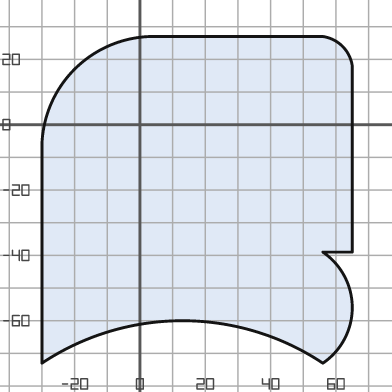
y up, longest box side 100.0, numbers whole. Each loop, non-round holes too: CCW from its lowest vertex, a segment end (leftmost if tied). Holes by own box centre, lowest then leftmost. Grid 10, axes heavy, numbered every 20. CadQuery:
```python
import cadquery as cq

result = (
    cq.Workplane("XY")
    .moveTo(-30.0, -73.0)
    .threePointArc((13.0, -60.0), (56.0, -73.0))
    .threePointArc((65.0, -56.0), (56.0, -39.0))
    .lineTo(65.0, -39.0)
    .lineTo(65.0, 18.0)
    .threePointArc((62.0, 24.0), (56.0, 27.0))
    .lineTo(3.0, 27.0)
    .threePointArc((-20.0, 17.0), (-30.0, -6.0))
    .close()
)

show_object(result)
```